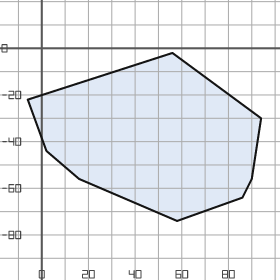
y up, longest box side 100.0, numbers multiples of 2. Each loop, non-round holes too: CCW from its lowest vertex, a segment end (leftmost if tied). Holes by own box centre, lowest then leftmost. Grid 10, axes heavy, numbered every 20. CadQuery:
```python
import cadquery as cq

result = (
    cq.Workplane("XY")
    .moveTo(58.0, -74.0)
    .lineTo(86.0, -64.0)
    .lineTo(90.0, -56.0)
    .lineTo(94.0, -30.0)
    .lineTo(56.0, -2.0)
    .lineTo(-6.0, -22.0)
    .lineTo(2.0, -44.0)
    .lineTo(16.0, -56.0)
    .close()
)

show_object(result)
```